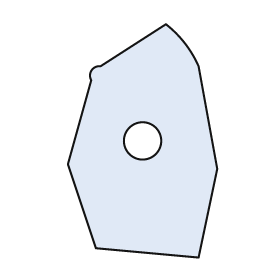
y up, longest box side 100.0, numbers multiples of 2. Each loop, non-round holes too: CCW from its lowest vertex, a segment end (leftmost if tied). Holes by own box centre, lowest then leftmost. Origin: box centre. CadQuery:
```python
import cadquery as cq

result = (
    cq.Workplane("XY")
    .moveTo(24.0, -50.0)
    .lineTo(32.0, -12.0)
    .lineTo(24.0, 32.0)
    .threePointArc((18.0, 42.0), (10.0, 50.0))
    .lineTo(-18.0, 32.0)
    .threePointArc((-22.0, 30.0), (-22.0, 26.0))
    .lineTo(-32.0, -10.0)
    .lineTo(-20.0, -46.0)
    .close()
    .moveTo(0.0, 0.0)
    .circle(8.0)
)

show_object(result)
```